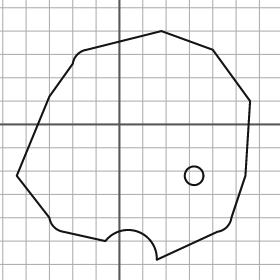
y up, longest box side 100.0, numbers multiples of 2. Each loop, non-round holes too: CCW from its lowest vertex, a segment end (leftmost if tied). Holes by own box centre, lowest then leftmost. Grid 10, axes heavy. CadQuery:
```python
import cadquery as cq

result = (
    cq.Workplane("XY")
    .moveTo(16.0, -58.0)
    .lineTo(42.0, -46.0)
    .threePointArc((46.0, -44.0), (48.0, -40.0))
    .lineTo(54.0, -22.0)
    .lineTo(56.0, 10.0)
    .lineTo(40.0, 32.0)
    .lineTo(18.0, 40.0)
    .lineTo(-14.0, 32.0)
    .threePointArc((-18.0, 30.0), (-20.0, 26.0))
    .lineTo(-30.0, 12.0)
    .lineTo(-44.0, -22.0)
    .lineTo(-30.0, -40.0)
    .threePointArc((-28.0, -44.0), (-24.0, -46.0))
    .lineTo(-6.0, -50.0)
    .threePointArc((8.0, -46.0), (16.0, -58.0))
    .close()
    .moveTo(32.0, -22.0)
    .circle(4.0)
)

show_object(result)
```